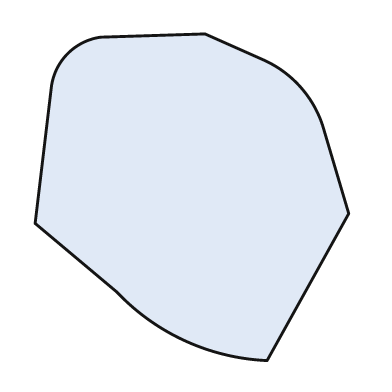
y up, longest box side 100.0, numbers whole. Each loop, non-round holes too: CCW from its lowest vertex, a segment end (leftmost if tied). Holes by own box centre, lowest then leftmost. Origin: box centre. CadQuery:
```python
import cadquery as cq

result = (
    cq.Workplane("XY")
    .moveTo(23.0, -50.0)
    .lineTo(48.0, -5.0)
    .lineTo(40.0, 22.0)
    .threePointArc((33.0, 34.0), (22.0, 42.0))
    .lineTo(4.0, 50.0)
    .lineTo(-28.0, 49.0)
    .threePointArc((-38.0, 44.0), (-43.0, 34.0))
    .lineTo(-48.0, -8.0)
    .lineTo(-23.0, -29.0)
    .threePointArc((-2.0, -44.0), (23.0, -50.0))
    .close()
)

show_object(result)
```